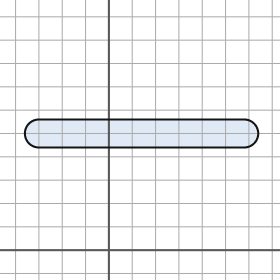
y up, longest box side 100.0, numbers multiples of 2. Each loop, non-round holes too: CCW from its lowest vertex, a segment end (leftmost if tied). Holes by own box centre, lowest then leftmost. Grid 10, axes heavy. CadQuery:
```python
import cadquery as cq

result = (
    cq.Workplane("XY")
    .moveTo(-30.0, 44.0)
    .lineTo(58.0, 44.0)
    .threePointArc((64.0, 50.0), (58.0, 56.0))
    .lineTo(-30.0, 56.0)
    .threePointArc((-36.0, 50.0), (-30.0, 44.0))
    .close()
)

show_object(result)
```